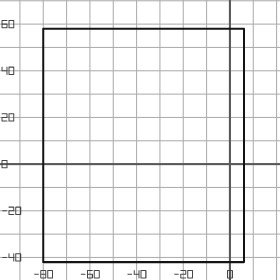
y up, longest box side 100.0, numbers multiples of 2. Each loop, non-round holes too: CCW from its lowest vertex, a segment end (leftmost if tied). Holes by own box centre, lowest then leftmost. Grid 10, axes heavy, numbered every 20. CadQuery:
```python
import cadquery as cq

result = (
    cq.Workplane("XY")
    .moveTo(-80.0, -42.0)
    .lineTo(6.0, -42.0)
    .lineTo(6.0, 58.0)
    .lineTo(-80.0, 58.0)
    .close()
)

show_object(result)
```